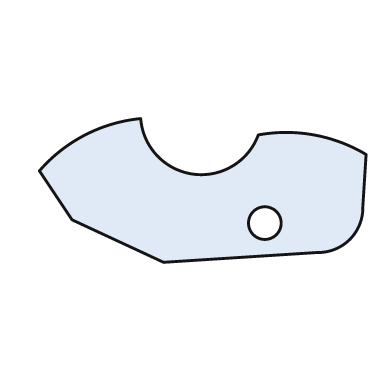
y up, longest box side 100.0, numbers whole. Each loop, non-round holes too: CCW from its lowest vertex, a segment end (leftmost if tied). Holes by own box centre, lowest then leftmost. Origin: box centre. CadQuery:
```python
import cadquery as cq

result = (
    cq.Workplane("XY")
    .moveTo(-12.0, -22.0)
    .lineTo(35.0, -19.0)
    .threePointArc((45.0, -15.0), (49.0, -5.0))
    .lineTo(50.0, 11.0)
    .threePointArc((34.0, 17.0), (17.0, 17.0))
    .threePointArc((-3.0, 5.0), (-19.0, 22.0))
    .threePointArc((-36.0, 17.0), (-50.0, 6.0))
    .lineTo(-40.0, -9.0)
    .close()
    .moveTo(19.0, -10.0)
    .circle(5.0)
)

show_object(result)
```